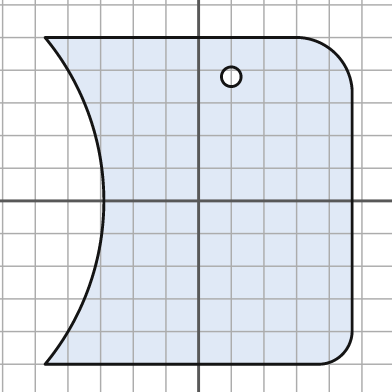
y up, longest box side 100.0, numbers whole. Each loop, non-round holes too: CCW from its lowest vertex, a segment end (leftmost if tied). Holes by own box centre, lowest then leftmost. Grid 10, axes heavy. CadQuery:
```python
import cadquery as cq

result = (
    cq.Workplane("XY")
    .moveTo(-47.0, -50.0)
    .lineTo(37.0, -50.0)
    .threePointArc((44.0, -47.0), (47.0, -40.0))
    .lineTo(47.0, 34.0)
    .threePointArc((42.0, 45.0), (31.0, 50.0))
    .lineTo(-47.0, 50.0)
    .threePointArc((-29.0, 0.0), (-47.0, -50.0))
    .close()
    .moveTo(10.0, 38.0)
    .circle(3.0)
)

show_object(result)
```